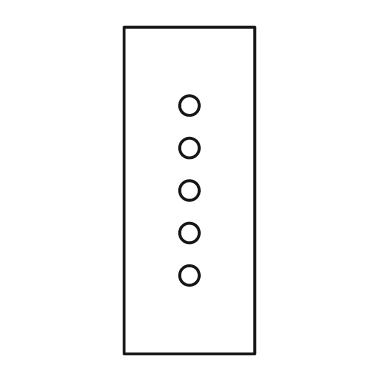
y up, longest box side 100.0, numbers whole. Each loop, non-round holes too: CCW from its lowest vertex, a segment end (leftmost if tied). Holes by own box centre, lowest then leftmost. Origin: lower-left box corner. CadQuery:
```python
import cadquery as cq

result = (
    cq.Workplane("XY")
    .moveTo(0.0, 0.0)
    .lineTo(40.0, 0.0)
    .lineTo(40.0, 100.0)
    .lineTo(0.0, 100.0)
    .close()
    .moveTo(20.0, 24.0)
    .circle(3.0)
    .moveTo(20.0, 37.0)
    .circle(3.0)
    .moveTo(20.0, 50.0)
    .circle(3.0)
    .moveTo(20.0, 63.0)
    .circle(3.0)
    .moveTo(20.0, 76.0)
    .circle(3.0)
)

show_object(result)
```